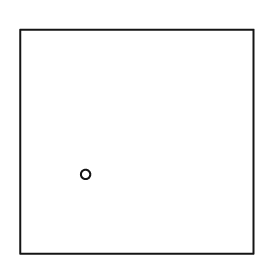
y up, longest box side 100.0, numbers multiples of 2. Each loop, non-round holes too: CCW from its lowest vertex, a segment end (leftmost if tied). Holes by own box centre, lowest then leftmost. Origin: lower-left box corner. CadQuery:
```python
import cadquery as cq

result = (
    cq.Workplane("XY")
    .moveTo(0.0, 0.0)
    .lineTo(100.0, 0.0)
    .lineTo(100.0, 96.0)
    .lineTo(0.0, 96.0)
    .close()
    .moveTo(28.0, 34.0)
    .circle(2.0)
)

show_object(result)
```